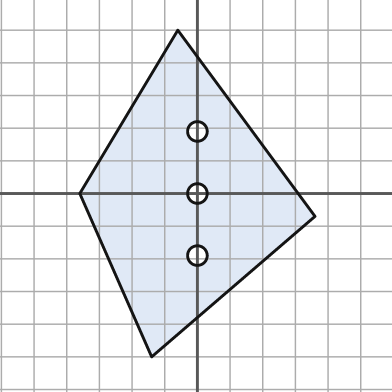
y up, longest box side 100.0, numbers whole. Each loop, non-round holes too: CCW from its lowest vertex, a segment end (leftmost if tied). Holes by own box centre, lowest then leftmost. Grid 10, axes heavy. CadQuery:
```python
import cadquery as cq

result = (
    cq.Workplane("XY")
    .moveTo(-14.0, -50.0)
    .lineTo(36.0, -7.0)
    .lineTo(-6.0, 50.0)
    .lineTo(-36.0, 0.0)
    .close()
    .moveTo(0.0, -19.0)
    .circle(3.0)
    .moveTo(0.0, 0.0)
    .circle(3.0)
    .moveTo(0.0, 19.0)
    .circle(3.0)
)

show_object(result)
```